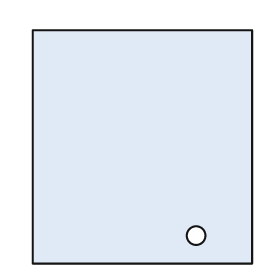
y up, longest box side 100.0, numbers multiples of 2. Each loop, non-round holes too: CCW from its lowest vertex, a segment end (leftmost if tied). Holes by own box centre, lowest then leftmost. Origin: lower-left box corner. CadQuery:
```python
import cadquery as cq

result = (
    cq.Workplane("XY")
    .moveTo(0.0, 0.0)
    .lineTo(94.0, 0.0)
    .lineTo(94.0, 100.0)
    .lineTo(0.0, 100.0)
    .close()
    .moveTo(70.0, 12.0)
    .circle(4.0)
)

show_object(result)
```